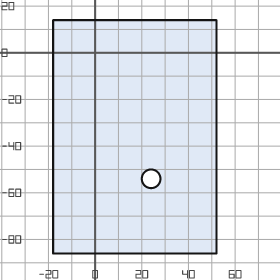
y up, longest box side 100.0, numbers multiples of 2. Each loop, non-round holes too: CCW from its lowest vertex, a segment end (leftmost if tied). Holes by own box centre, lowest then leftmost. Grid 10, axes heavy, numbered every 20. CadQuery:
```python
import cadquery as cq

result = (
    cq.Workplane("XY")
    .moveTo(-18.0, -86.0)
    .lineTo(52.0, -86.0)
    .lineTo(52.0, 14.0)
    .lineTo(-18.0, 14.0)
    .close()
    .moveTo(24.0, -54.0)
    .circle(4.0)
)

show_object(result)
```